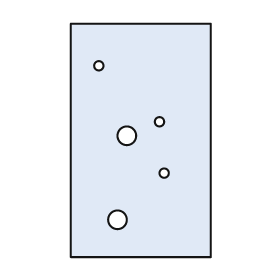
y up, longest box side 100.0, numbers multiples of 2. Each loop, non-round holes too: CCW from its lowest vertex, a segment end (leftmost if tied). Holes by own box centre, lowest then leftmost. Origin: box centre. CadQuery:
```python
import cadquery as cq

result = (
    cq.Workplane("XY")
    .moveTo(-30.0, -50.0)
    .lineTo(30.0, -50.0)
    .lineTo(30.0, 50.0)
    .lineTo(-30.0, 50.0)
    .close()
    .moveTo(-10.0, -34.0)
    .circle(4.0)
    .moveTo(10.0, -14.0)
    .circle(2.0)
    .moveTo(-6.0, 2.0)
    .circle(4.0)
    .moveTo(8.0, 8.0)
    .circle(2.0)
    .moveTo(-18.0, 32.0)
    .circle(2.0)
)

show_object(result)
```